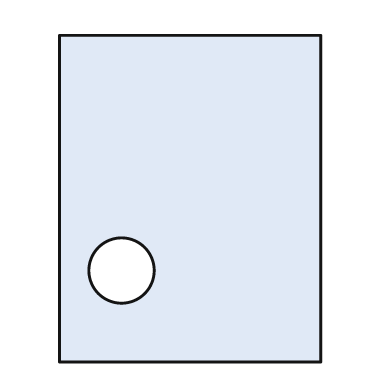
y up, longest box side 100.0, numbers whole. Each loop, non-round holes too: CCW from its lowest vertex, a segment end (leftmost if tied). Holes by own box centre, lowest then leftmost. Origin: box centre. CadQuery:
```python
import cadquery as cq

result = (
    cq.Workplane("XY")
    .moveTo(-40.0, -50.0)
    .lineTo(40.0, -50.0)
    .lineTo(40.0, 50.0)
    .lineTo(-40.0, 50.0)
    .close()
    .moveTo(-21.0, -22.0)
    .circle(10.0)
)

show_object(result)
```